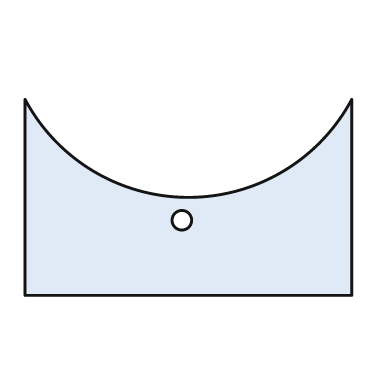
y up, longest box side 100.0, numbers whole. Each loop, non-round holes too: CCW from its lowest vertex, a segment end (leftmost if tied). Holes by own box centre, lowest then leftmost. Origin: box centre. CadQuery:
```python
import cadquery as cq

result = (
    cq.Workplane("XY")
    .moveTo(-50.0, -30.0)
    .lineTo(50.0, -30.0)
    .lineTo(50.0, 30.0)
    .threePointArc((0.0, 0.0), (-50.0, 30.0))
    .close()
    .moveTo(-2.0, -7.0)
    .circle(3.0)
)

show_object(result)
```